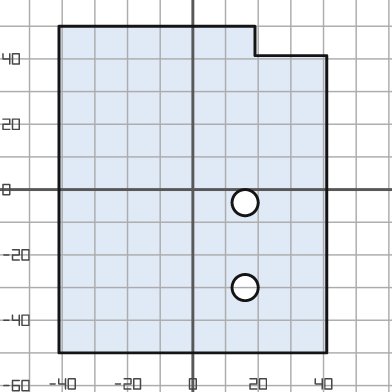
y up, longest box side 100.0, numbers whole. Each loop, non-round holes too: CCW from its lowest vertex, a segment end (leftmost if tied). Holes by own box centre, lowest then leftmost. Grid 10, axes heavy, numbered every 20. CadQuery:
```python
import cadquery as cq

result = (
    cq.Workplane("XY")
    .moveTo(-41.0, -50.0)
    .lineTo(41.0, -50.0)
    .lineTo(41.0, 41.0)
    .lineTo(19.0, 41.0)
    .lineTo(19.0, 50.0)
    .lineTo(-41.0, 50.0)
    .close()
    .moveTo(16.0, -30.0)
    .circle(4.0)
    .moveTo(16.0, -4.0)
    .circle(4.0)
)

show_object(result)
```